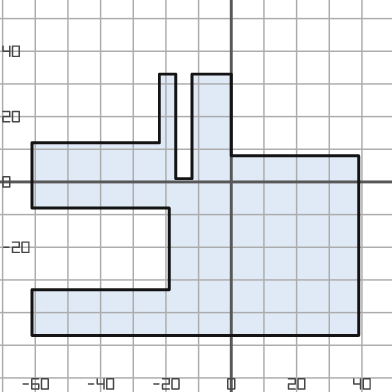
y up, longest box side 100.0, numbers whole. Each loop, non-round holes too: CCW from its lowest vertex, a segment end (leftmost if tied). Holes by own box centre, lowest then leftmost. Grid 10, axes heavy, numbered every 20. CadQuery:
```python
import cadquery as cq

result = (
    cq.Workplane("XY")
    .moveTo(-61.0, -47.0)
    .lineTo(39.0, -47.0)
    .lineTo(39.0, 8.0)
    .lineTo(0.0, 8.0)
    .lineTo(0.0, 33.0)
    .lineTo(-12.0, 33.0)
    .lineTo(-12.0, 1.0)
    .lineTo(-17.0, 1.0)
    .lineTo(-17.0, 33.0)
    .lineTo(-22.0, 33.0)
    .lineTo(-22.0, 12.0)
    .lineTo(-61.0, 12.0)
    .lineTo(-61.0, -8.0)
    .lineTo(-19.0, -8.0)
    .lineTo(-19.0, -33.0)
    .lineTo(-61.0, -33.0)
    .close()
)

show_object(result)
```